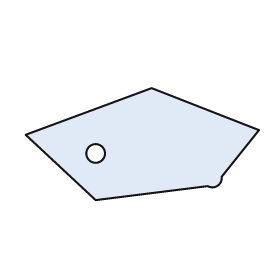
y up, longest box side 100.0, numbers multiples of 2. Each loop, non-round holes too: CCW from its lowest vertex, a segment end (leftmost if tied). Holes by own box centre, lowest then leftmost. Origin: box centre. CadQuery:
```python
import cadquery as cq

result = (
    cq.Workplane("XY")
    .moveTo(-20.0, -24.0)
    .lineTo(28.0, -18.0)
    .threePointArc((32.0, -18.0), (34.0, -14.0))
    .lineTo(50.0, 6.0)
    .lineTo(4.0, 24.0)
    .lineTo(-50.0, 4.0)
    .close()
    .moveTo(-20.0, -4.0)
    .circle(4.0)
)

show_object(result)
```